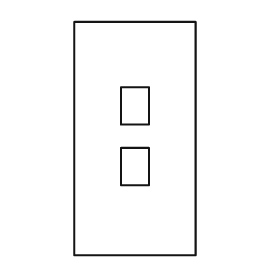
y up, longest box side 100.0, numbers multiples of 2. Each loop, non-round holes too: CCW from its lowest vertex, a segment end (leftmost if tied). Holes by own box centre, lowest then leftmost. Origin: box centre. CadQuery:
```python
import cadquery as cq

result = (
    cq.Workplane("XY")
    .moveTo(-26.0, -50.0)
    .lineTo(26.0, -50.0)
    .lineTo(26.0, 50.0)
    .lineTo(-26.0, 50.0)
    .close()
    .moveTo(-6.0, -20.0)
    .lineTo(6.0, -20.0)
    .lineTo(6.0, -4.0)
    .lineTo(-6.0, -4.0)
    .close()
    .moveTo(-6.0, 6.0)
    .lineTo(6.0, 6.0)
    .lineTo(6.0, 22.0)
    .lineTo(-6.0, 22.0)
    .close()
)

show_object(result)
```